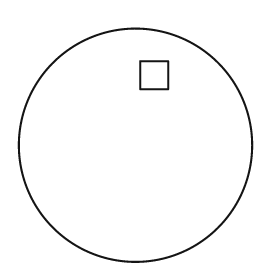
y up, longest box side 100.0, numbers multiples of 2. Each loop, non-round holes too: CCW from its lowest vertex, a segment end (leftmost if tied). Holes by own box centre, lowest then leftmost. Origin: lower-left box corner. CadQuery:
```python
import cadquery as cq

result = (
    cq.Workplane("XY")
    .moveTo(50.0, 50.0)
    .circle(50.0)
    .moveTo(52.0, 74.0)
    .lineTo(64.0, 74.0)
    .lineTo(64.0, 86.0)
    .lineTo(52.0, 86.0)
    .close()
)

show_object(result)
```